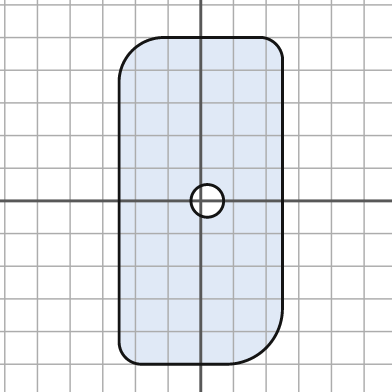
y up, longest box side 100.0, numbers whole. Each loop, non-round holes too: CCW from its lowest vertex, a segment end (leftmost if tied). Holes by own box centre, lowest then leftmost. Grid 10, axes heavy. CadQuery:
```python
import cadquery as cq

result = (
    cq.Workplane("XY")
    .moveTo(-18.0, -50.0)
    .lineTo(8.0, -50.0)
    .threePointArc((20.0, -45.0), (25.0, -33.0))
    .lineTo(25.0, 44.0)
    .threePointArc((23.0, 48.0), (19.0, 50.0))
    .lineTo(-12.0, 50.0)
    .threePointArc((-21.0, 46.0), (-25.0, 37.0))
    .lineTo(-25.0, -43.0)
    .threePointArc((-23.0, -48.0), (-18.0, -50.0))
    .close()
    .moveTo(2.0, 0.0)
    .circle(5.0)
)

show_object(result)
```